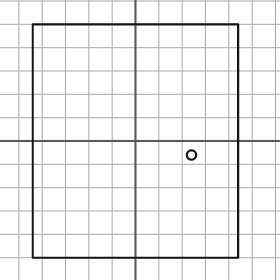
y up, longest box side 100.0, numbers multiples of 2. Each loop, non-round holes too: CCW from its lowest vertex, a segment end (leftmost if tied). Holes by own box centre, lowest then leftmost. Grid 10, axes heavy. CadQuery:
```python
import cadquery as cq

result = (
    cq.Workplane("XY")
    .moveTo(-44.0, -50.0)
    .lineTo(44.0, -50.0)
    .lineTo(44.0, 50.0)
    .lineTo(-44.0, 50.0)
    .close()
    .moveTo(24.0, -6.0)
    .circle(2.0)
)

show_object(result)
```